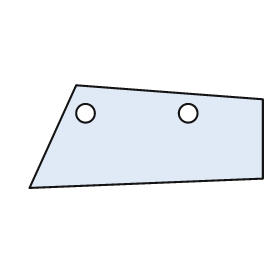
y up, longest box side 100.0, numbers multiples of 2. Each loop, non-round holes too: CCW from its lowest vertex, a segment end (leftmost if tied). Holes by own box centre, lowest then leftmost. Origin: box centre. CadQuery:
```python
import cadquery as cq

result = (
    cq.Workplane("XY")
    .moveTo(-50.0, -22.0)
    .lineTo(50.0, -18.0)
    .lineTo(50.0, 16.0)
    .lineTo(-30.0, 22.0)
    .close()
    .moveTo(-26.0, 10.0)
    .circle(4.0)
    .moveTo(18.0, 10.0)
    .circle(4.0)
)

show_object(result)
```